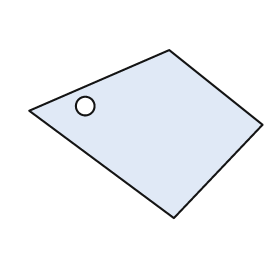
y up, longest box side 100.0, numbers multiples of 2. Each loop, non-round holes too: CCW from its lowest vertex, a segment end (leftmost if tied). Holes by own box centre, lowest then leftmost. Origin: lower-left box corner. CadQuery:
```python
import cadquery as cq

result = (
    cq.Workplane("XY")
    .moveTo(62.0, 0.0)
    .lineTo(100.0, 40.0)
    .lineTo(60.0, 72.0)
    .lineTo(0.0, 46.0)
    .close()
    .moveTo(24.0, 48.0)
    .circle(4.0)
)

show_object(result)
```